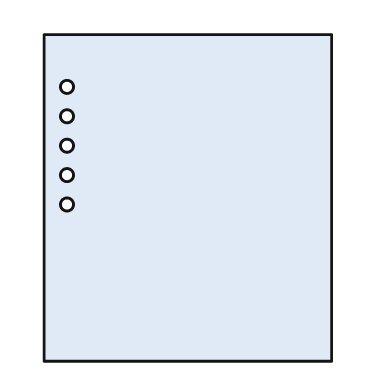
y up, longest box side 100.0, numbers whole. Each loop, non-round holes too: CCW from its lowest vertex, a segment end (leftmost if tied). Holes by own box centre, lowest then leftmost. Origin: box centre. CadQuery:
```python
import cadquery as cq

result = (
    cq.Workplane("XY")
    .moveTo(-44.0, -50.0)
    .lineTo(44.0, -50.0)
    .lineTo(44.0, 50.0)
    .lineTo(-44.0, 50.0)
    .close()
    .moveTo(-37.0, -2.0)
    .circle(2.0)
    .moveTo(-37.0, 7.0)
    .circle(2.0)
    .moveTo(-37.0, 16.0)
    .circle(2.0)
    .moveTo(-37.0, 25.0)
    .circle(2.0)
    .moveTo(-37.0, 34.0)
    .circle(2.0)
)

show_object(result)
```